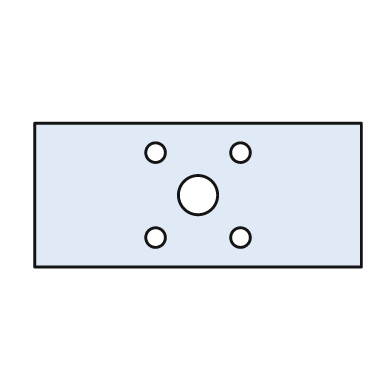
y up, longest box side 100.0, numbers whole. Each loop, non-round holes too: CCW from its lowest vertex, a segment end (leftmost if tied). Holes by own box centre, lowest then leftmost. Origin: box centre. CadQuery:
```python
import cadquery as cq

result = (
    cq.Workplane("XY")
    .moveTo(-50.0, -22.0)
    .lineTo(50.0, -22.0)
    .lineTo(50.0, 22.0)
    .lineTo(-50.0, 22.0)
    .close()
    .moveTo(-13.0, -13.0)
    .circle(3.0)
    .moveTo(13.0, -13.0)
    .circle(3.0)
    .moveTo(0.0, 0.0)
    .circle(6.0)
    .moveTo(-13.0, 13.0)
    .circle(3.0)
    .moveTo(13.0, 13.0)
    .circle(3.0)
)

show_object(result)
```